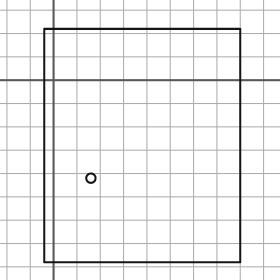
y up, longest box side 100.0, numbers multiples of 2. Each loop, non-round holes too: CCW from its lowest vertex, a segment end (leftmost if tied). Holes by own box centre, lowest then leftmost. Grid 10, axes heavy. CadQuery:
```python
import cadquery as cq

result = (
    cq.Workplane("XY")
    .moveTo(-4.0, -78.0)
    .lineTo(80.0, -78.0)
    .lineTo(80.0, 22.0)
    .lineTo(-4.0, 22.0)
    .close()
    .moveTo(16.0, -42.0)
    .circle(2.0)
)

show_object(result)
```